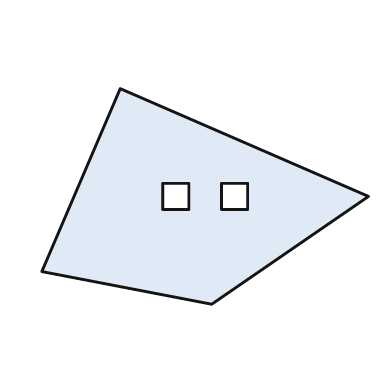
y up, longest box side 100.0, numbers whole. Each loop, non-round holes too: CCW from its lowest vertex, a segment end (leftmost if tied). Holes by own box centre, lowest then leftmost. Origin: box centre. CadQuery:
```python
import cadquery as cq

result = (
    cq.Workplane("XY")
    .moveTo(2.0, -33.0)
    .lineTo(50.0, 0.0)
    .lineTo(-26.0, 33.0)
    .lineTo(-50.0, -23.0)
    .close()
    .moveTo(-13.0, -4.0)
    .lineTo(-5.0, -4.0)
    .lineTo(-5.0, 4.0)
    .lineTo(-13.0, 4.0)
    .close()
    .moveTo(5.0, -4.0)
    .lineTo(13.0, -4.0)
    .lineTo(13.0, 4.0)
    .lineTo(5.0, 4.0)
    .close()
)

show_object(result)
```